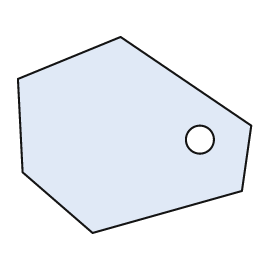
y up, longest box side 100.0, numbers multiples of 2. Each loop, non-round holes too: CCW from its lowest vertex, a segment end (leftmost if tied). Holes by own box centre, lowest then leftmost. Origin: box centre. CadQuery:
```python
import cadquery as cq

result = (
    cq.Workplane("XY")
    .moveTo(-18.0, -42.0)
    .lineTo(46.0, -24.0)
    .lineTo(50.0, 4.0)
    .lineTo(-6.0, 42.0)
    .lineTo(-50.0, 24.0)
    .lineTo(-48.0, -16.0)
    .close()
    .moveTo(28.0, -2.0)
    .circle(6.0)
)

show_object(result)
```